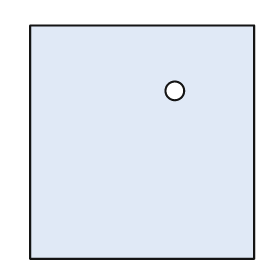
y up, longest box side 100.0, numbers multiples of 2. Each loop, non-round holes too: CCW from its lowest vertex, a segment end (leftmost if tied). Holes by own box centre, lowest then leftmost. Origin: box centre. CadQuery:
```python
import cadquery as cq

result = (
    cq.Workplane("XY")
    .moveTo(-48.0, -50.0)
    .lineTo(48.0, -50.0)
    .lineTo(48.0, 50.0)
    .lineTo(-48.0, 50.0)
    .close()
    .moveTo(14.0, 22.0)
    .circle(4.0)
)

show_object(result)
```